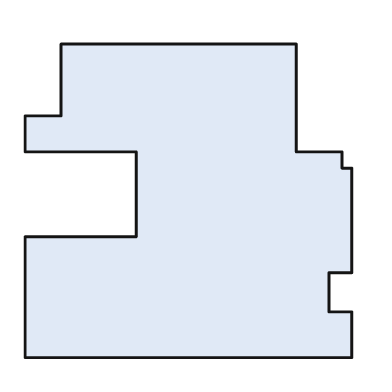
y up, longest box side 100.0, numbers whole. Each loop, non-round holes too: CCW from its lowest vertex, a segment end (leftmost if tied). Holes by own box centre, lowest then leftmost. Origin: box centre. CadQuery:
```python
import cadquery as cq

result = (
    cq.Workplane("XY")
    .moveTo(-50.0, -48.0)
    .lineTo(50.0, -48.0)
    .lineTo(50.0, -34.0)
    .lineTo(43.0, -34.0)
    .lineTo(43.0, -22.0)
    .lineTo(50.0, -22.0)
    .lineTo(50.0, 10.0)
    .lineTo(47.0, 10.0)
    .lineTo(47.0, 15.0)
    .lineTo(33.0, 15.0)
    .lineTo(33.0, 48.0)
    .lineTo(-39.0, 48.0)
    .lineTo(-39.0, 26.0)
    .lineTo(-50.0, 26.0)
    .lineTo(-50.0, 15.0)
    .lineTo(-16.0, 15.0)
    .lineTo(-16.0, -11.0)
    .lineTo(-50.0, -11.0)
    .close()
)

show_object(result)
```